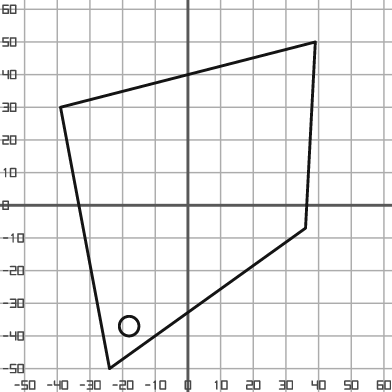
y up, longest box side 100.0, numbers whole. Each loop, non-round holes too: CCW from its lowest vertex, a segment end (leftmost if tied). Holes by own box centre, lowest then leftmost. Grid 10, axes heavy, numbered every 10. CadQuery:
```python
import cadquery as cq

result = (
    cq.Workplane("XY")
    .moveTo(-24.0, -50.0)
    .lineTo(36.0, -7.0)
    .lineTo(39.0, 50.0)
    .lineTo(-39.0, 30.0)
    .close()
    .moveTo(-18.0, -37.0)
    .circle(3.0)
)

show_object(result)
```